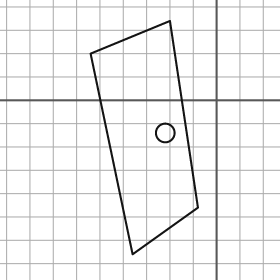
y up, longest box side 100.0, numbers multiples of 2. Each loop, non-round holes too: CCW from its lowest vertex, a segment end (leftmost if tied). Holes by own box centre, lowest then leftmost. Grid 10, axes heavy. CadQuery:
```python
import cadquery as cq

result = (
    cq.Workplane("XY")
    .moveTo(-36.0, -66.0)
    .lineTo(-8.0, -46.0)
    .lineTo(-20.0, 34.0)
    .lineTo(-54.0, 20.0)
    .close()
    .moveTo(-22.0, -14.0)
    .circle(4.0)
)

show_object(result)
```